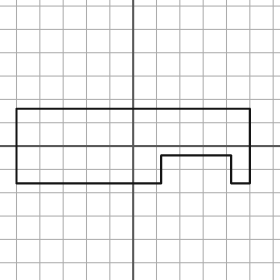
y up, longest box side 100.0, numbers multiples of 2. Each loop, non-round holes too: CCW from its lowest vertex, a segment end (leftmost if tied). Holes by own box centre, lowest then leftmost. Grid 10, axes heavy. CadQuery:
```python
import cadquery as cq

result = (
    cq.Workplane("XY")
    .moveTo(-50.0, -16.0)
    .lineTo(12.0, -16.0)
    .lineTo(12.0, -4.0)
    .lineTo(42.0, -4.0)
    .lineTo(42.0, -16.0)
    .lineTo(50.0, -16.0)
    .lineTo(50.0, 16.0)
    .lineTo(-50.0, 16.0)
    .close()
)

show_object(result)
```